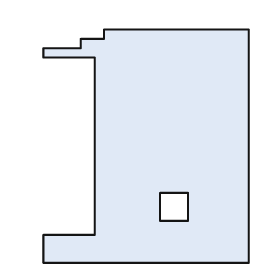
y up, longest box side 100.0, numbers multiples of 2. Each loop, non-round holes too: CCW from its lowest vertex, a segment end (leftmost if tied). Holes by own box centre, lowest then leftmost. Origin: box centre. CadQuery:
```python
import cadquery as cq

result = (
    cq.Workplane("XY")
    .moveTo(-44.0, -50.0)
    .lineTo(44.0, -50.0)
    .lineTo(44.0, 50.0)
    .lineTo(-18.0, 50.0)
    .lineTo(-18.0, 46.0)
    .lineTo(-28.0, 46.0)
    .lineTo(-28.0, 42.0)
    .lineTo(-44.0, 42.0)
    .lineTo(-44.0, 38.0)
    .lineTo(-22.0, 38.0)
    .lineTo(-22.0, -38.0)
    .lineTo(-44.0, -38.0)
    .close()
    .moveTo(6.0, -32.0)
    .lineTo(18.0, -32.0)
    .lineTo(18.0, -20.0)
    .lineTo(6.0, -20.0)
    .close()
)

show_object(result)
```